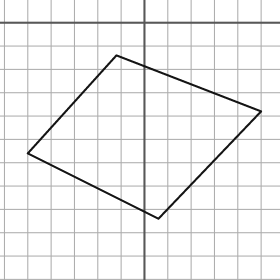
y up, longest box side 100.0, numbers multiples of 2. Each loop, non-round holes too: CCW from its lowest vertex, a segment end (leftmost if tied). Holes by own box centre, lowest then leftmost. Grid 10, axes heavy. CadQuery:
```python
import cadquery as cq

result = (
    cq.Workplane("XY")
    .moveTo(6.0, -84.0)
    .lineTo(50.0, -38.0)
    .lineTo(-12.0, -14.0)
    .lineTo(-50.0, -56.0)
    .close()
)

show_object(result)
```